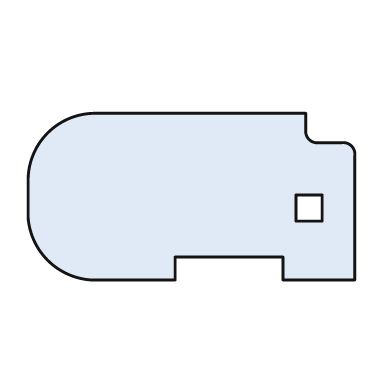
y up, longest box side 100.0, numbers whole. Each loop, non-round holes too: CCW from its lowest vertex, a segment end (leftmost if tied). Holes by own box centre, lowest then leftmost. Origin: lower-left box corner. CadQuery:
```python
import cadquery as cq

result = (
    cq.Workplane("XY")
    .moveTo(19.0, 0.0)
    .lineTo(45.0, 0.0)
    .lineTo(45.0, 7.0)
    .lineTo(78.0, 7.0)
    .lineTo(78.0, 0.0)
    .lineTo(100.0, 0.0)
    .lineTo(100.0, 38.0)
    .threePointArc((99.0, 41.0), (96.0, 42.0))
    .lineTo(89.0, 42.0)
    .threePointArc((86.0, 43.0), (85.0, 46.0))
    .lineTo(85.0, 51.0)
    .lineTo(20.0, 51.0)
    .threePointArc((6.0, 45.0), (0.0, 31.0))
    .lineTo(0.0, 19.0)
    .threePointArc((6.0, 6.0), (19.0, 0.0))
    .close()
    .moveTo(82.0, 18.0)
    .lineTo(90.0, 18.0)
    .lineTo(90.0, 26.0)
    .lineTo(82.0, 26.0)
    .close()
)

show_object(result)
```